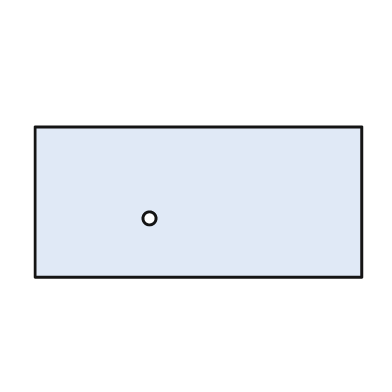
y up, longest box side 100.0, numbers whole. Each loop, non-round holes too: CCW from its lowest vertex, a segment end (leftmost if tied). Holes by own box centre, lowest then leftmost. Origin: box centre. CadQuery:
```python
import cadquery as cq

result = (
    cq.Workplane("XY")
    .moveTo(-50.0, -23.0)
    .lineTo(50.0, -23.0)
    .lineTo(50.0, 23.0)
    .lineTo(-50.0, 23.0)
    .close()
    .moveTo(-15.0, -5.0)
    .circle(2.0)
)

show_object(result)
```